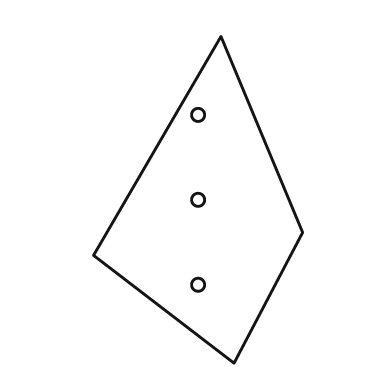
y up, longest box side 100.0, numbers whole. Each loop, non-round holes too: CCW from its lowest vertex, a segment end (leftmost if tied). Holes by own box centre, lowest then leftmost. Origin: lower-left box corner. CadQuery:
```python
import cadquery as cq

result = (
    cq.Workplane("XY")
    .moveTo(43.0, 0.0)
    .lineTo(64.0, 40.0)
    .lineTo(39.0, 100.0)
    .lineTo(0.0, 33.0)
    .close()
    .moveTo(32.0, 24.0)
    .circle(2.0)
    .moveTo(32.0, 50.0)
    .circle(2.0)
    .moveTo(32.0, 76.0)
    .circle(2.0)
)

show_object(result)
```